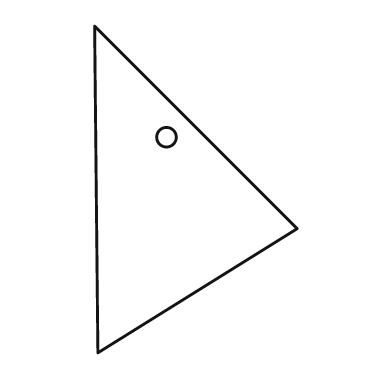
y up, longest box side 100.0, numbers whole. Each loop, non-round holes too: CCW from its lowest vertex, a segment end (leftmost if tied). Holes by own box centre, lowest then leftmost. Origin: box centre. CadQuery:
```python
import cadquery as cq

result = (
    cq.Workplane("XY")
    .moveTo(-30.0, -50.0)
    .lineTo(31.0, -12.0)
    .lineTo(-31.0, 50.0)
    .close()
    .moveTo(-9.0, 16.0)
    .circle(3.0)
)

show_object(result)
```